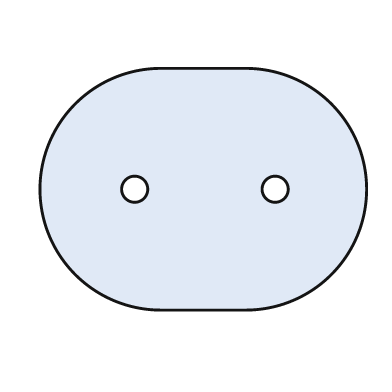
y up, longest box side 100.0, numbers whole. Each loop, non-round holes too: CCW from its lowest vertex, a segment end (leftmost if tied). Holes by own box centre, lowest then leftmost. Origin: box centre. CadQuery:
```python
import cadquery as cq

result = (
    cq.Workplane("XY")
    .moveTo(-13.0, -37.0)
    .lineTo(13.0, -37.0)
    .threePointArc((50.0, 0.0), (13.0, 37.0))
    .lineTo(-13.0, 37.0)
    .threePointArc((-50.0, 0.0), (-13.0, -37.0))
    .close()
    .moveTo(-21.0, 0.0)
    .circle(4.0)
    .moveTo(22.0, 0.0)
    .circle(4.0)
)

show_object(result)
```